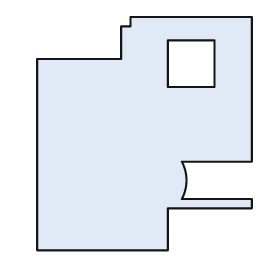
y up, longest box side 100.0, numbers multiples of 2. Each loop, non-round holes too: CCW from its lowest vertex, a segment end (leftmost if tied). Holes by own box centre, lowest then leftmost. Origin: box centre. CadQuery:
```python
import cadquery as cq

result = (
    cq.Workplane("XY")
    .moveTo(-46.0, -50.0)
    .lineTo(10.0, -50.0)
    .lineTo(10.0, -32.0)
    .lineTo(46.0, -32.0)
    .lineTo(46.0, -28.0)
    .lineTo(16.0, -28.0)
    .threePointArc((18.0, -20.0), (16.0, -12.0))
    .lineTo(46.0, -12.0)
    .lineTo(46.0, 50.0)
    .lineTo(-6.0, 50.0)
    .lineTo(-6.0, 46.0)
    .lineTo(-10.0, 46.0)
    .lineTo(-10.0, 32.0)
    .lineTo(-46.0, 32.0)
    .close()
    .moveTo(10.0, 20.0)
    .lineTo(30.0, 20.0)
    .lineTo(30.0, 40.0)
    .lineTo(10.0, 40.0)
    .close()
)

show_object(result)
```